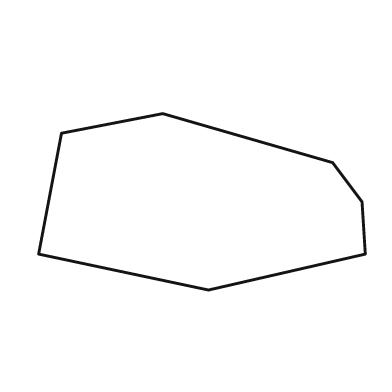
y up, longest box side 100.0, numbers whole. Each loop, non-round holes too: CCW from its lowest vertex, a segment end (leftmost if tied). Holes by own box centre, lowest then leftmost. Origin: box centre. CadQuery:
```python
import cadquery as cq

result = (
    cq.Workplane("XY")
    .moveTo(2.0, -27.0)
    .lineTo(50.0, -16.0)
    .lineTo(49.0, 0.0)
    .lineTo(40.0, 12.0)
    .lineTo(-12.0, 27.0)
    .lineTo(-43.0, 21.0)
    .lineTo(-50.0, -16.0)
    .close()
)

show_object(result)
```